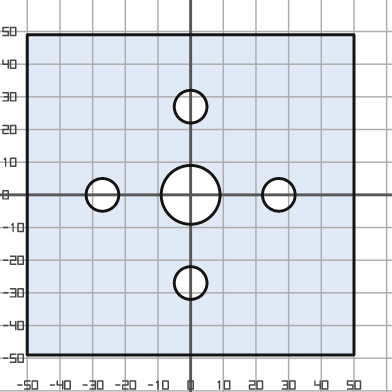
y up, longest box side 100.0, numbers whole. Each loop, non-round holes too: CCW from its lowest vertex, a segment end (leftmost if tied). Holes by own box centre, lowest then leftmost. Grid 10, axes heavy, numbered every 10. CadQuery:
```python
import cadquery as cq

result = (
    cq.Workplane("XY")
    .moveTo(-50.0, -49.0)
    .lineTo(50.0, -49.0)
    .lineTo(50.0, 49.0)
    .lineTo(-50.0, 49.0)
    .close()
    .moveTo(0.0, -27.0)
    .circle(5.0)
    .moveTo(-27.0, 0.0)
    .circle(5.0)
    .moveTo(0.0, 0.0)
    .circle(9.0)
    .moveTo(27.0, 0.0)
    .circle(5.0)
    .moveTo(0.0, 27.0)
    .circle(5.0)
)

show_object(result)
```